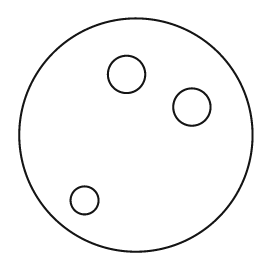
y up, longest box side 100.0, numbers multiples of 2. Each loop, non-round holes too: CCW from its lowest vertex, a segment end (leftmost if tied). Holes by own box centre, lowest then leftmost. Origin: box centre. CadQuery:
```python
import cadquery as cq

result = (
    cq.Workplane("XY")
    .moveTo(0.0, 0.0)
    .circle(50.0)
    .moveTo(-22.0, -28.0)
    .circle(6.0)
    .moveTo(24.0, 12.0)
    .circle(8.0)
    .moveTo(-4.0, 26.0)
    .circle(8.0)
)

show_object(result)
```